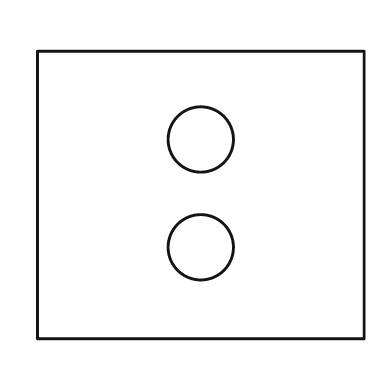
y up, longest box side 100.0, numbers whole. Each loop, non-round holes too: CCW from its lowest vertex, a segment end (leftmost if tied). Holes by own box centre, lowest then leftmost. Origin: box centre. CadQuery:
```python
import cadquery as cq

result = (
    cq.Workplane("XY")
    .moveTo(-50.0, -44.0)
    .lineTo(50.0, -44.0)
    .lineTo(50.0, 44.0)
    .lineTo(-50.0, 44.0)
    .close()
    .moveTo(0.0, -16.0)
    .circle(10.0)
    .moveTo(0.0, 17.0)
    .circle(10.0)
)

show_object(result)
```